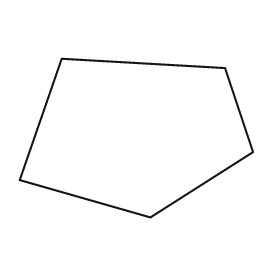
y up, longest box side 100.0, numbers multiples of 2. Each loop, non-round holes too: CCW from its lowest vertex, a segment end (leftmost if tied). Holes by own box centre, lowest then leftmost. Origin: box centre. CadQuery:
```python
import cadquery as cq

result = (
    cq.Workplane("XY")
    .moveTo(6.0, -34.0)
    .lineTo(50.0, -6.0)
    .lineTo(38.0, 30.0)
    .lineTo(-32.0, 34.0)
    .lineTo(-50.0, -18.0)
    .close()
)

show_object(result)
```